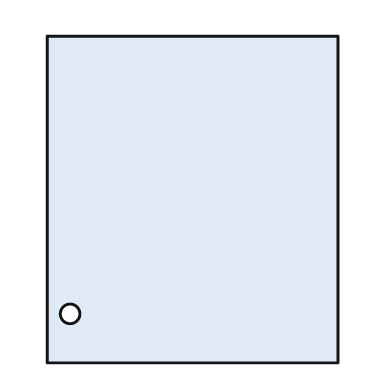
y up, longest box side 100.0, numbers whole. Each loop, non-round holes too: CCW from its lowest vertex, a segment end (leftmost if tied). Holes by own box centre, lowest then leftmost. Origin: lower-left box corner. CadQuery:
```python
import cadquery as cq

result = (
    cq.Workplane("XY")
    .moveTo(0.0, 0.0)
    .lineTo(89.0, 0.0)
    .lineTo(89.0, 100.0)
    .lineTo(0.0, 100.0)
    .close()
    .moveTo(7.0, 15.0)
    .circle(3.0)
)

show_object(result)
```